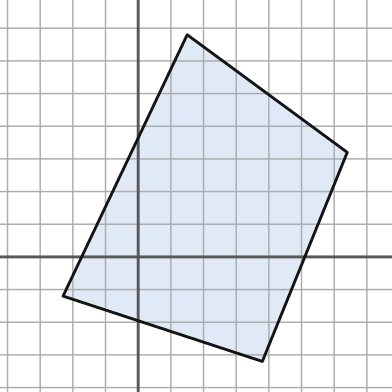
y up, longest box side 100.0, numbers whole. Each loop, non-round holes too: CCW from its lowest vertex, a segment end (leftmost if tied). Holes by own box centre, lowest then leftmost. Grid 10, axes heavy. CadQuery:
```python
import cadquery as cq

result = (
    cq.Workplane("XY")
    .moveTo(38.0, -32.0)
    .lineTo(64.0, 32.0)
    .lineTo(15.0, 68.0)
    .lineTo(-23.0, -12.0)
    .close()
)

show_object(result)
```